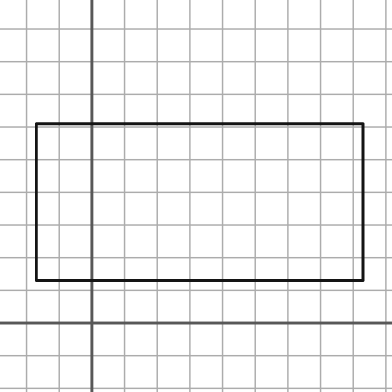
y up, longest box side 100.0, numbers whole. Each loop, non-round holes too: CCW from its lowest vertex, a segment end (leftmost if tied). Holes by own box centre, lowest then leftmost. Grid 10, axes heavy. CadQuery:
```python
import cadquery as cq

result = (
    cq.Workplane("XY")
    .moveTo(-17.0, 13.0)
    .lineTo(83.0, 13.0)
    .lineTo(83.0, 61.0)
    .lineTo(-17.0, 61.0)
    .close()
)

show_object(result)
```